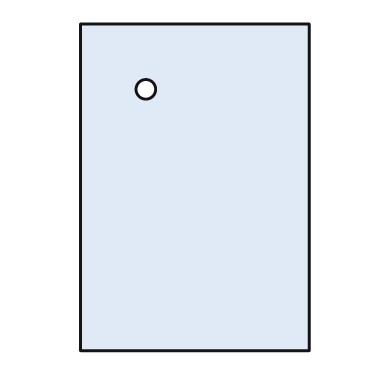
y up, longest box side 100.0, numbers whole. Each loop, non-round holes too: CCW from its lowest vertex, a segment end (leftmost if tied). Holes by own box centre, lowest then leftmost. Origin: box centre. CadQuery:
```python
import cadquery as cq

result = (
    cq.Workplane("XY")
    .moveTo(-35.0, -50.0)
    .lineTo(35.0, -50.0)
    .lineTo(35.0, 50.0)
    .lineTo(-35.0, 50.0)
    .close()
    .moveTo(-15.0, 30.0)
    .circle(3.0)
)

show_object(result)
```